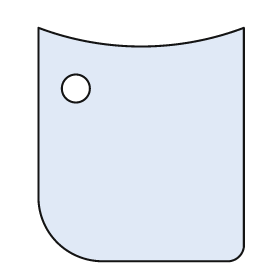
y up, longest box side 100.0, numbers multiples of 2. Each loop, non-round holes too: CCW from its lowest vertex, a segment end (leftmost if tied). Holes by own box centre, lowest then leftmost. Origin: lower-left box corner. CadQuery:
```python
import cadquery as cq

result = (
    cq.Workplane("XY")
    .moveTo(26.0, 0.0)
    .lineTo(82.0, 0.0)
    .threePointArc((86.0, 2.0), (88.0, 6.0))
    .lineTo(88.0, 100.0)
    .threePointArc((44.0, 92.0), (0.0, 100.0))
    .lineTo(0.0, 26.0)
    .threePointArc((8.0, 8.0), (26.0, 0.0))
    .close()
    .moveTo(16.0, 74.0)
    .circle(6.0)
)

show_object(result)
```